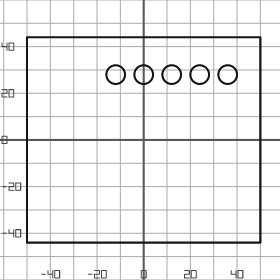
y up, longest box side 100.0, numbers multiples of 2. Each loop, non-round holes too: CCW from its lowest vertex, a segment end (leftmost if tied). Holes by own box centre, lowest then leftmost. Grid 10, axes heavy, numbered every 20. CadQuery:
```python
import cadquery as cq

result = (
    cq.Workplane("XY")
    .moveTo(-50.0, -44.0)
    .lineTo(50.0, -44.0)
    .lineTo(50.0, 44.0)
    .lineTo(-50.0, 44.0)
    .close()
    .moveTo(-12.0, 28.0)
    .circle(4.0)
    .moveTo(0.0, 28.0)
    .circle(4.0)
    .moveTo(12.0, 28.0)
    .circle(4.0)
    .moveTo(24.0, 28.0)
    .circle(4.0)
    .moveTo(36.0, 28.0)
    .circle(4.0)
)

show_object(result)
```